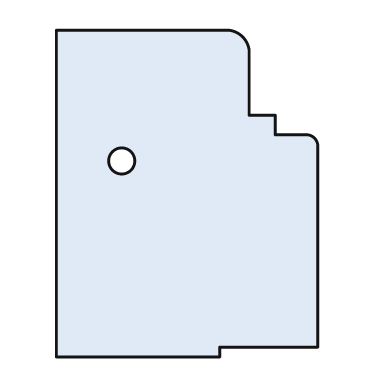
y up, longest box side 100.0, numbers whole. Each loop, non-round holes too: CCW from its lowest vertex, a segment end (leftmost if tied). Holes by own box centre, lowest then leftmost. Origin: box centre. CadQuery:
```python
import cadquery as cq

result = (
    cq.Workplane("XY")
    .moveTo(-40.0, -50.0)
    .lineTo(10.0, -50.0)
    .lineTo(10.0, -47.0)
    .lineTo(40.0, -47.0)
    .lineTo(40.0, 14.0)
    .threePointArc((39.0, 17.0), (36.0, 18.0))
    .lineTo(27.0, 18.0)
    .lineTo(27.0, 24.0)
    .lineTo(19.0, 24.0)
    .lineTo(19.0, 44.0)
    .threePointArc((17.0, 48.0), (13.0, 50.0))
    .lineTo(-40.0, 50.0)
    .close()
    .moveTo(-20.0, 10.0)
    .circle(4.0)
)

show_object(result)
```